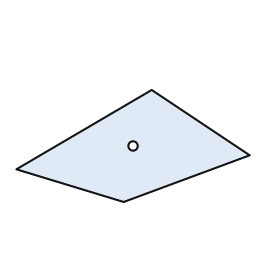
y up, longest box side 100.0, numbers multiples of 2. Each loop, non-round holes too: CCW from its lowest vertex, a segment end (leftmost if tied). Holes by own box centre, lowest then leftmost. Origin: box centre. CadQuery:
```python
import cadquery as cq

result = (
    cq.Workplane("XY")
    .moveTo(-4.0, -24.0)
    .lineTo(50.0, -4.0)
    .lineTo(8.0, 24.0)
    .lineTo(-50.0, -10.0)
    .close()
    .moveTo(0.0, 0.0)
    .circle(2.0)
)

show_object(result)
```